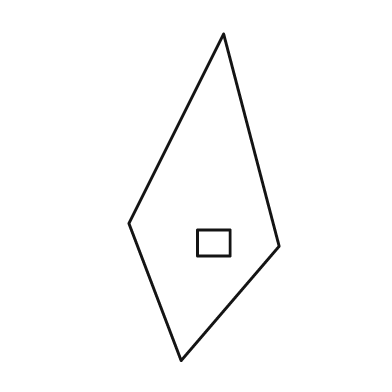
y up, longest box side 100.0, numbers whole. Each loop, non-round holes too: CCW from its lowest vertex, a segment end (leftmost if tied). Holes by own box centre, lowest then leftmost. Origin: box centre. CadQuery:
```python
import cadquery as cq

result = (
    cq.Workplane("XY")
    .moveTo(-7.0, -50.0)
    .lineTo(23.0, -15.0)
    .lineTo(6.0, 50.0)
    .lineTo(-23.0, -8.0)
    .close()
    .moveTo(-2.0, -18.0)
    .lineTo(8.0, -18.0)
    .lineTo(8.0, -10.0)
    .lineTo(-2.0, -10.0)
    .close()
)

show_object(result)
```